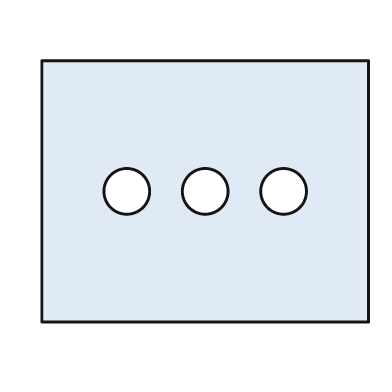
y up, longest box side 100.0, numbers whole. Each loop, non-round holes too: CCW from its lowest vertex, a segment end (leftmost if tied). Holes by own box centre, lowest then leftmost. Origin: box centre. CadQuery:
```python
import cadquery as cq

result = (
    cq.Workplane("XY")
    .moveTo(-50.0, -40.0)
    .lineTo(50.0, -40.0)
    .lineTo(50.0, 40.0)
    .lineTo(-50.0, 40.0)
    .close()
    .moveTo(-24.0, 0.0)
    .circle(7.0)
    .moveTo(0.0, 0.0)
    .circle(7.0)
    .moveTo(24.0, 0.0)
    .circle(7.0)
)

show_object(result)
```